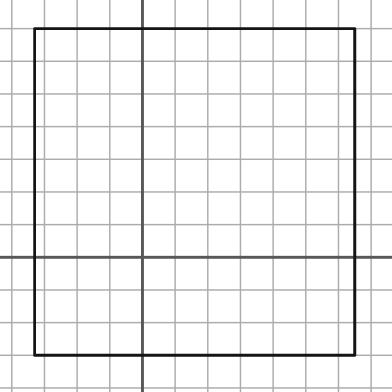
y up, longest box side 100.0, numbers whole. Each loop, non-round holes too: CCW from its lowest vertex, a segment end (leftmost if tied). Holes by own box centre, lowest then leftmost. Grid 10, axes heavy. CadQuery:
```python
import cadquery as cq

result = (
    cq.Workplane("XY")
    .moveTo(-33.0, -30.0)
    .lineTo(65.0, -30.0)
    .lineTo(65.0, 70.0)
    .lineTo(-33.0, 70.0)
    .close()
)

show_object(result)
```